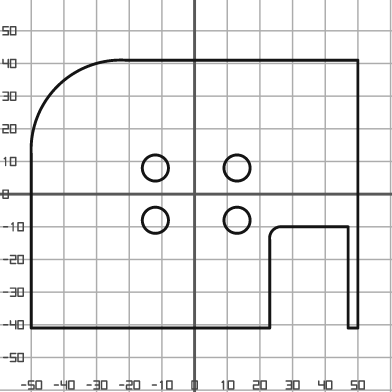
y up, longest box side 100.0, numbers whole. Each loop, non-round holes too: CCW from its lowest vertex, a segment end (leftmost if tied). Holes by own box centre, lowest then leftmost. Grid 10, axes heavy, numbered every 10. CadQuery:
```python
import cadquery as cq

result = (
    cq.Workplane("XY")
    .moveTo(-50.0, -41.0)
    .lineTo(23.0, -41.0)
    .lineTo(23.0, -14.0)
    .threePointArc((24.0, -11.0), (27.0, -10.0))
    .lineTo(47.0, -10.0)
    .lineTo(47.0, -41.0)
    .lineTo(50.0, -41.0)
    .lineTo(50.0, 41.0)
    .lineTo(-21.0, 41.0)
    .threePointArc((-42.0, 33.0), (-50.0, 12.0))
    .close()
    .moveTo(-12.0, -8.0)
    .circle(4.0)
    .moveTo(13.0, -8.0)
    .circle(4.0)
    .moveTo(-12.0, 8.0)
    .circle(4.0)
    .moveTo(13.0, 8.0)
    .circle(4.0)
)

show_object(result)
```